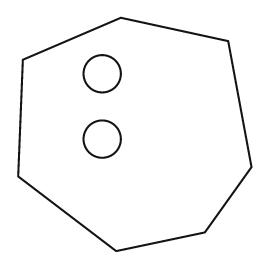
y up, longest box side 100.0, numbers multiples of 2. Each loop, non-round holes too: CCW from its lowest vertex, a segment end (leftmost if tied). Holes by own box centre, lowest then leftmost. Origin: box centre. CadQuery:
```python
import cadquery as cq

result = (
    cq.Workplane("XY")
    .moveTo(-8.0, -50.0)
    .lineTo(30.0, -42.0)
    .lineTo(50.0, -14.0)
    .lineTo(40.0, 40.0)
    .lineTo(-6.0, 50.0)
    .lineTo(-48.0, 32.0)
    .lineTo(-50.0, -18.0)
    .close()
    .moveTo(-14.0, -2.0)
    .circle(8.0)
    .moveTo(-14.0, 26.0)
    .circle(8.0)
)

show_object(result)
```